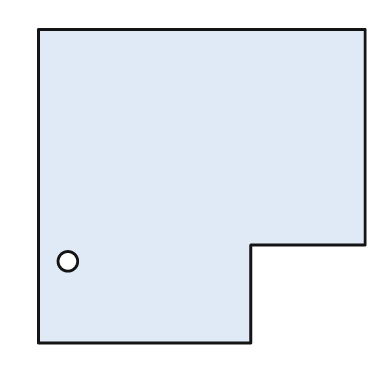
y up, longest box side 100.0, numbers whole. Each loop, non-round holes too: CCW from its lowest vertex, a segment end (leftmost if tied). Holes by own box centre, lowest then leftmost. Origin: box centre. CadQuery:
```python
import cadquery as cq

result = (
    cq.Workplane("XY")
    .moveTo(-50.0, -48.0)
    .lineTo(15.0, -48.0)
    .lineTo(15.0, -18.0)
    .lineTo(50.0, -18.0)
    .lineTo(50.0, 48.0)
    .lineTo(-50.0, 48.0)
    .close()
    .moveTo(-41.0, -23.0)
    .circle(3.0)
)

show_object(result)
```